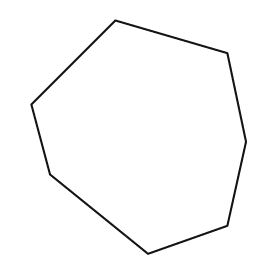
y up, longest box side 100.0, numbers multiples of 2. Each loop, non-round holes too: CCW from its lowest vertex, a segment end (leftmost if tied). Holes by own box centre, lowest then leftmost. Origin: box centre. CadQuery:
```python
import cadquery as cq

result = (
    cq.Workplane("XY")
    .moveTo(4.0, -50.0)
    .lineTo(38.0, -38.0)
    .lineTo(46.0, -2.0)
    .lineTo(38.0, 36.0)
    .lineTo(-10.0, 50.0)
    .lineTo(-46.0, 14.0)
    .lineTo(-38.0, -16.0)
    .close()
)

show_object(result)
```